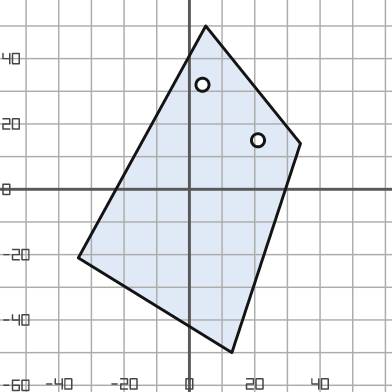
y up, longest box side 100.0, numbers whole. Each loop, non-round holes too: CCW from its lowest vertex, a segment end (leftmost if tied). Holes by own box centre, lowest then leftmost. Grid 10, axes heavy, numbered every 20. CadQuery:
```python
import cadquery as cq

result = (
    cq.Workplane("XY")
    .moveTo(13.0, -50.0)
    .lineTo(34.0, 14.0)
    .lineTo(5.0, 50.0)
    .lineTo(-34.0, -21.0)
    .close()
    .moveTo(21.0, 15.0)
    .circle(2.0)
    .moveTo(4.0, 32.0)
    .circle(2.0)
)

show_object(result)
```